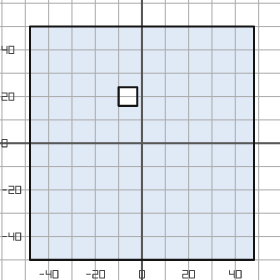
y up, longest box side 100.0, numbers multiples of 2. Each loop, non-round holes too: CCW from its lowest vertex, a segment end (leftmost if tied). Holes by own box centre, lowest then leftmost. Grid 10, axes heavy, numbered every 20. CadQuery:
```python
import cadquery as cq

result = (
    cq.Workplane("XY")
    .moveTo(-48.0, -50.0)
    .lineTo(48.0, -50.0)
    .lineTo(48.0, 50.0)
    .lineTo(-48.0, 50.0)
    .close()
    .moveTo(-10.0, 16.0)
    .lineTo(-2.0, 16.0)
    .lineTo(-2.0, 24.0)
    .lineTo(-10.0, 24.0)
    .close()
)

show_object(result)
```